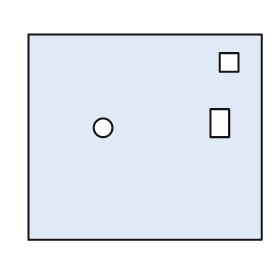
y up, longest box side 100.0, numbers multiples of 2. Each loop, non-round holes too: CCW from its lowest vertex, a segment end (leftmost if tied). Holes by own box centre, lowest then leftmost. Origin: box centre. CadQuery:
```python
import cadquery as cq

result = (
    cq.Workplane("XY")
    .moveTo(-50.0, -44.0)
    .lineTo(50.0, -44.0)
    .lineTo(50.0, 44.0)
    .lineTo(-50.0, 44.0)
    .close()
    .moveTo(-18.0, 4.0)
    .circle(4.0)
    .moveTo(28.0, 0.0)
    .lineTo(36.0, 0.0)
    .lineTo(36.0, 12.0)
    .lineTo(28.0, 12.0)
    .close()
    .moveTo(32.0, 28.0)
    .lineTo(40.0, 28.0)
    .lineTo(40.0, 36.0)
    .lineTo(32.0, 36.0)
    .close()
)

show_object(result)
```